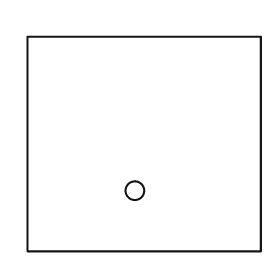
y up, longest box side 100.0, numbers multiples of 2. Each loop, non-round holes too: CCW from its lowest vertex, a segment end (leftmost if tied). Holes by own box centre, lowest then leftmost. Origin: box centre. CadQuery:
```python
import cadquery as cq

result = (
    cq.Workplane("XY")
    .moveTo(-50.0, -46.0)
    .lineTo(50.0, -46.0)
    .lineTo(50.0, 46.0)
    .lineTo(-50.0, 46.0)
    .close()
    .moveTo(-4.0, -20.0)
    .circle(4.0)
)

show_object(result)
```